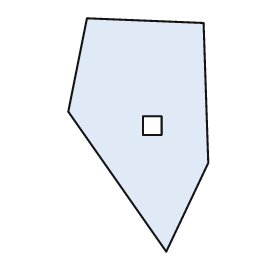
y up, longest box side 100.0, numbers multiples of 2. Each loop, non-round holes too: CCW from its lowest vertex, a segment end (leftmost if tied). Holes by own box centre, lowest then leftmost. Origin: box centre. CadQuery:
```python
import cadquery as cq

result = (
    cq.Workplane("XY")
    .moveTo(12.0, -50.0)
    .lineTo(30.0, -12.0)
    .lineTo(28.0, 48.0)
    .lineTo(-22.0, 50.0)
    .lineTo(-30.0, 10.0)
    .close()
    .moveTo(2.0, 0.0)
    .lineTo(10.0, 0.0)
    .lineTo(10.0, 8.0)
    .lineTo(2.0, 8.0)
    .close()
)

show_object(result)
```